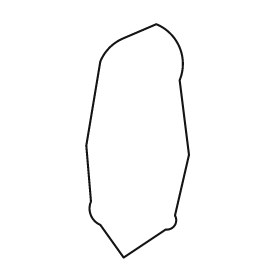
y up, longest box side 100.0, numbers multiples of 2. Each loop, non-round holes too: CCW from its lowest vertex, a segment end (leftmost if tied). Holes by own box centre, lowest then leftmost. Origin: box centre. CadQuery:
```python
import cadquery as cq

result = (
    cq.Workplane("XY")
    .moveTo(-6.0, -50.0)
    .lineTo(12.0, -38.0)
    .threePointArc((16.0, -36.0), (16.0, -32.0))
    .lineTo(22.0, -6.0)
    .lineTo(18.0, 26.0)
    .threePointArc((18.0, 40.0), (8.0, 50.0))
    .lineTo(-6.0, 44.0)
    .threePointArc((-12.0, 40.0), (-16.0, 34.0))
    .lineTo(-22.0, -2.0)
    .lineTo(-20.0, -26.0)
    .threePointArc((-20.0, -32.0), (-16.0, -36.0))
    .close()
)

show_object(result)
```